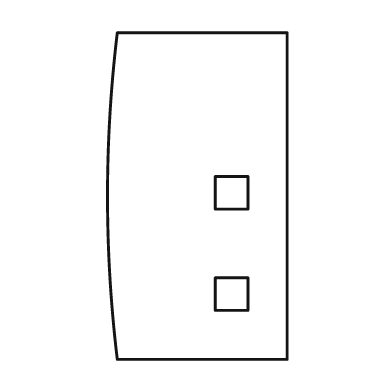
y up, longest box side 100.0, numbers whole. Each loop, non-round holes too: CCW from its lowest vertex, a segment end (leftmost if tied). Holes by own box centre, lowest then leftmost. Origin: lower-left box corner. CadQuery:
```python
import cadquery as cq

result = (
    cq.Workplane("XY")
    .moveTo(3.0, 0.0)
    .lineTo(55.0, 0.0)
    .lineTo(55.0, 100.0)
    .lineTo(3.0, 100.0)
    .threePointArc((0.0, 50.0), (3.0, 0.0))
    .close()
    .moveTo(33.0, 15.0)
    .lineTo(43.0, 15.0)
    .lineTo(43.0, 25.0)
    .lineTo(33.0, 25.0)
    .close()
    .moveTo(33.0, 46.0)
    .lineTo(43.0, 46.0)
    .lineTo(43.0, 56.0)
    .lineTo(33.0, 56.0)
    .close()
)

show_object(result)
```